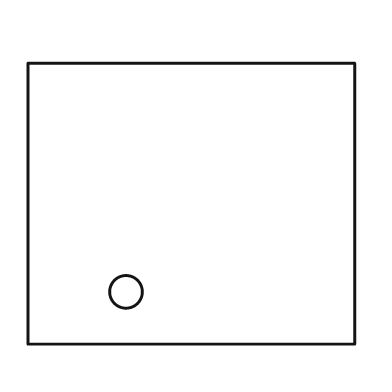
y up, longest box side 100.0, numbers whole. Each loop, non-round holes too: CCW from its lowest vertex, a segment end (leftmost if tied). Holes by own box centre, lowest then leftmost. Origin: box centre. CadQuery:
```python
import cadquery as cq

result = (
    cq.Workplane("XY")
    .moveTo(-50.0, -43.0)
    .lineTo(50.0, -43.0)
    .lineTo(50.0, 43.0)
    .lineTo(-50.0, 43.0)
    .close()
    .moveTo(-20.0, -27.0)
    .circle(5.0)
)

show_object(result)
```